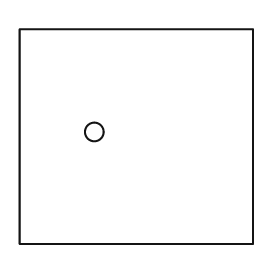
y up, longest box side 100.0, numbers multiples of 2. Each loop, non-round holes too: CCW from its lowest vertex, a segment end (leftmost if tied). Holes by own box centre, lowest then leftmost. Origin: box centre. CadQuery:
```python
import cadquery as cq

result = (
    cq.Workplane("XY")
    .moveTo(-50.0, -46.0)
    .lineTo(50.0, -46.0)
    .lineTo(50.0, 46.0)
    .lineTo(-50.0, 46.0)
    .close()
    .moveTo(-18.0, 2.0)
    .circle(4.0)
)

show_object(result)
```